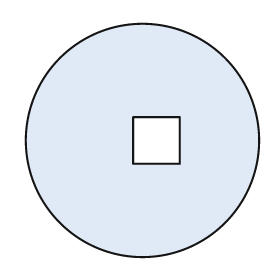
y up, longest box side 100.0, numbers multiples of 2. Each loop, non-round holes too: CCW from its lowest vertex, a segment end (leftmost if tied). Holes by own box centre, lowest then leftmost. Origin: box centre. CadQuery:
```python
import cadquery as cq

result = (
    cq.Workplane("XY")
    .moveTo(0.0, 0.0)
    .circle(50.0)
    .moveTo(-4.0, -10.0)
    .lineTo(16.0, -10.0)
    .lineTo(16.0, 10.0)
    .lineTo(-4.0, 10.0)
    .close()
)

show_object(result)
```